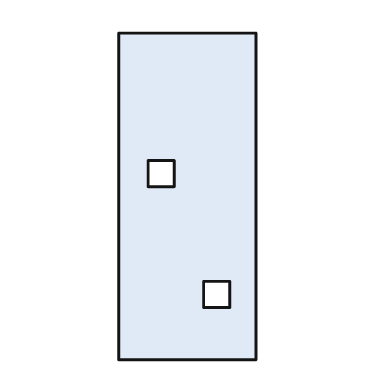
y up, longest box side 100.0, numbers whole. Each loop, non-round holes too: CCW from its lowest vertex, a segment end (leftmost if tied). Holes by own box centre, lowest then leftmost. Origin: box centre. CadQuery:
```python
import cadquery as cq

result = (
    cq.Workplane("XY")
    .moveTo(-21.0, -50.0)
    .lineTo(21.0, -50.0)
    .lineTo(21.0, 50.0)
    .lineTo(-21.0, 50.0)
    .close()
    .moveTo(5.0, -34.0)
    .lineTo(13.0, -34.0)
    .lineTo(13.0, -26.0)
    .lineTo(5.0, -26.0)
    .close()
    .moveTo(-12.0, 3.0)
    .lineTo(-4.0, 3.0)
    .lineTo(-4.0, 11.0)
    .lineTo(-12.0, 11.0)
    .close()
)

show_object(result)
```